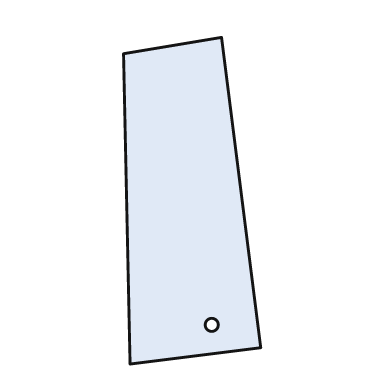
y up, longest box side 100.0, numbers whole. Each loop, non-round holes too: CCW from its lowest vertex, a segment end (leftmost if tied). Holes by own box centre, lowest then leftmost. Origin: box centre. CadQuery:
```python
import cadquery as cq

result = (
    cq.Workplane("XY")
    .moveTo(-19.0, -50.0)
    .lineTo(21.0, -45.0)
    .lineTo(9.0, 50.0)
    .lineTo(-21.0, 45.0)
    .close()
    .moveTo(6.0, -38.0)
    .circle(2.0)
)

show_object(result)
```